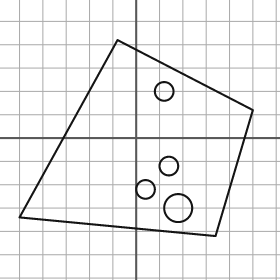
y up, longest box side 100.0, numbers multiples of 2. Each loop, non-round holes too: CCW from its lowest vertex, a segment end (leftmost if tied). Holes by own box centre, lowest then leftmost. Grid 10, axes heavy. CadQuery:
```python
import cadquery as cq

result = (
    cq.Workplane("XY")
    .moveTo(34.0, -42.0)
    .lineTo(50.0, 12.0)
    .lineTo(-8.0, 42.0)
    .lineTo(-50.0, -34.0)
    .close()
    .moveTo(18.0, -30.0)
    .circle(6.0)
    .moveTo(4.0, -22.0)
    .circle(4.0)
    .moveTo(14.0, -12.0)
    .circle(4.0)
    .moveTo(12.0, 20.0)
    .circle(4.0)
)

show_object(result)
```